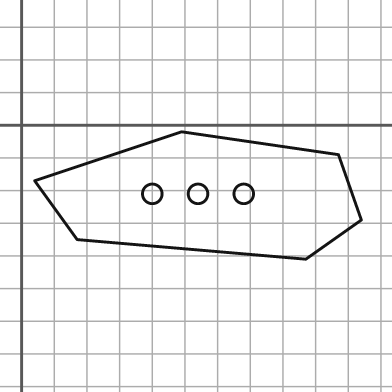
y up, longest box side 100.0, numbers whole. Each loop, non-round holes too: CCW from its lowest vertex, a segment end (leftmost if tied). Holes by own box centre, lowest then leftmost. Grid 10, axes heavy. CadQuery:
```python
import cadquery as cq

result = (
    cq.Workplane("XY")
    .moveTo(87.0, -41.0)
    .lineTo(104.0, -29.0)
    .lineTo(97.0, -9.0)
    .lineTo(49.0, -2.0)
    .lineTo(4.0, -17.0)
    .lineTo(17.0, -35.0)
    .close()
    .moveTo(40.0, -21.0)
    .circle(3.0)
    .moveTo(54.0, -21.0)
    .circle(3.0)
    .moveTo(68.0, -21.0)
    .circle(3.0)
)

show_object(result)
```